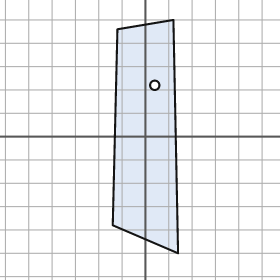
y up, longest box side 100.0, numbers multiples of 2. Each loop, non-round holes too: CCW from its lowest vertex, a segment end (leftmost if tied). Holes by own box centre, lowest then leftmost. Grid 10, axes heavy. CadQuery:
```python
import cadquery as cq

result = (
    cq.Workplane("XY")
    .moveTo(14.0, -50.0)
    .lineTo(12.0, 50.0)
    .lineTo(-12.0, 46.0)
    .lineTo(-14.0, -38.0)
    .close()
    .moveTo(4.0, 22.0)
    .circle(2.0)
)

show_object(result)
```